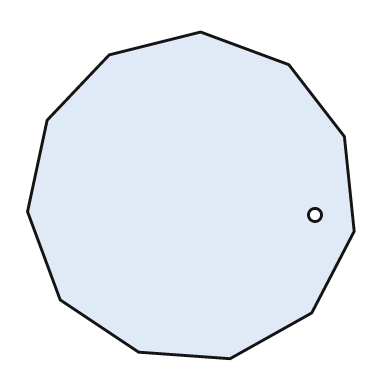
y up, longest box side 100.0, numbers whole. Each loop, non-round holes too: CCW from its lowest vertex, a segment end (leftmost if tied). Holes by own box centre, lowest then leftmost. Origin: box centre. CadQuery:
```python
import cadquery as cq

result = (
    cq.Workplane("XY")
    .moveTo(12.0, -50.0)
    .lineTo(37.0, -36.0)
    .lineTo(50.0, -11.0)
    .lineTo(47.0, 18.0)
    .lineTo(30.0, 40.0)
    .lineTo(3.0, 50.0)
    .lineTo(-25.0, 43.0)
    .lineTo(-44.0, 23.0)
    .lineTo(-50.0, -5.0)
    .lineTo(-40.0, -32.0)
    .lineTo(-16.0, -48.0)
    .close()
    .moveTo(38.0, -6.0)
    .circle(2.0)
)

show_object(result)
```